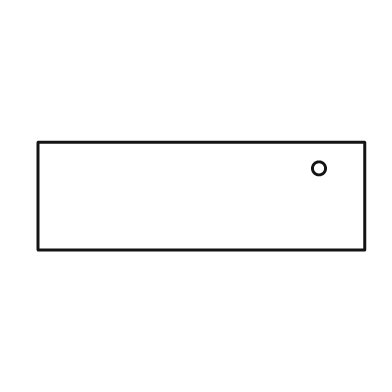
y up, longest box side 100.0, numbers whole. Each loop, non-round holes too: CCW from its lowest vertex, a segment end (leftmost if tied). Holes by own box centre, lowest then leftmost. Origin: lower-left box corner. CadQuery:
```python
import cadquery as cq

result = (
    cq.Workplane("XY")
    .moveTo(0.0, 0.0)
    .lineTo(100.0, 0.0)
    .lineTo(100.0, 33.0)
    .lineTo(0.0, 33.0)
    .close()
    .moveTo(86.0, 25.0)
    .circle(2.0)
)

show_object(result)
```